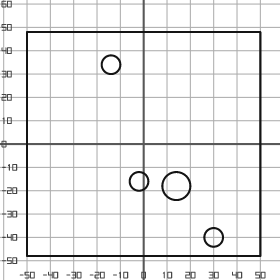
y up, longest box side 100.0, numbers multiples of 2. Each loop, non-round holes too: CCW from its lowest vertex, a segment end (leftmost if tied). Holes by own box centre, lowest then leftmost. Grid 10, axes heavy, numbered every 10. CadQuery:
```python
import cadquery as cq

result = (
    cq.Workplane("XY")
    .moveTo(-50.0, -48.0)
    .lineTo(50.0, -48.0)
    .lineTo(50.0, 48.0)
    .lineTo(-50.0, 48.0)
    .close()
    .moveTo(30.0, -40.0)
    .circle(4.0)
    .moveTo(14.0, -18.0)
    .circle(6.0)
    .moveTo(-2.0, -16.0)
    .circle(4.0)
    .moveTo(-14.0, 34.0)
    .circle(4.0)
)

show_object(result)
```